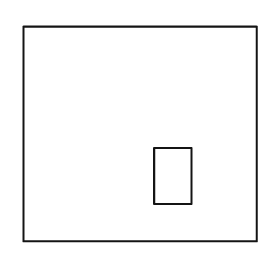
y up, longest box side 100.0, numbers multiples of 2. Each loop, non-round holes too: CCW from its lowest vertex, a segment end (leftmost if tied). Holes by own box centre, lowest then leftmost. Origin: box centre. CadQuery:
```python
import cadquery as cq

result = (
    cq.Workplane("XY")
    .moveTo(-50.0, -46.0)
    .lineTo(50.0, -46.0)
    .lineTo(50.0, 46.0)
    .lineTo(-50.0, 46.0)
    .close()
    .moveTo(6.0, -30.0)
    .lineTo(22.0, -30.0)
    .lineTo(22.0, -6.0)
    .lineTo(6.0, -6.0)
    .close()
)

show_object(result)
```